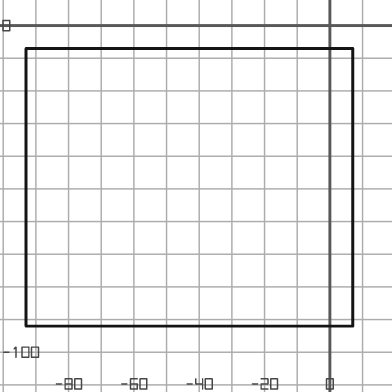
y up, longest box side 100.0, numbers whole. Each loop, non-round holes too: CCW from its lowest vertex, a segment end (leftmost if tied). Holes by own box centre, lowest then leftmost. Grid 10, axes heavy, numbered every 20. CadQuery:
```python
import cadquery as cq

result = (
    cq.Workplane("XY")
    .moveTo(-93.0, -92.0)
    .lineTo(7.0, -92.0)
    .lineTo(7.0, -7.0)
    .lineTo(-93.0, -7.0)
    .close()
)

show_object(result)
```